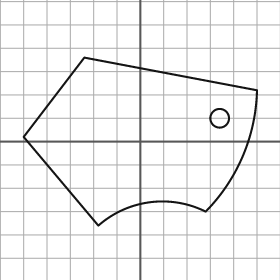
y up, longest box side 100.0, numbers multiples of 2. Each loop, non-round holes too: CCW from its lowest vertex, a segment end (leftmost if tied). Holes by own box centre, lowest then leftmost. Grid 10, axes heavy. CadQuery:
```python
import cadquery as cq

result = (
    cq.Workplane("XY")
    .moveTo(-18.0, -36.0)
    .threePointArc((4.0, -26.0), (28.0, -30.0))
    .threePointArc((44.0, -6.0), (50.0, 22.0))
    .lineTo(-24.0, 36.0)
    .lineTo(-50.0, 2.0)
    .close()
    .moveTo(34.0, 10.0)
    .circle(4.0)
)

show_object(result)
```